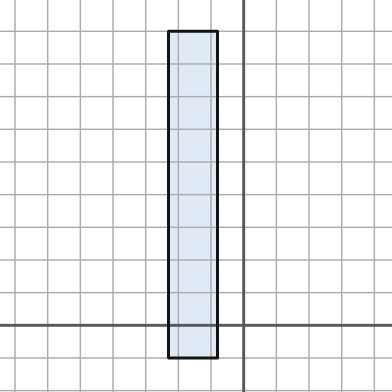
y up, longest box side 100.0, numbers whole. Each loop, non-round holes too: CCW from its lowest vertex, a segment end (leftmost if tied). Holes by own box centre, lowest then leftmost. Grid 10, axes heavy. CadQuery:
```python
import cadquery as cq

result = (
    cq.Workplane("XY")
    .moveTo(-23.0, -10.0)
    .lineTo(-8.0, -10.0)
    .lineTo(-8.0, 90.0)
    .lineTo(-23.0, 90.0)
    .close()
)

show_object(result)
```